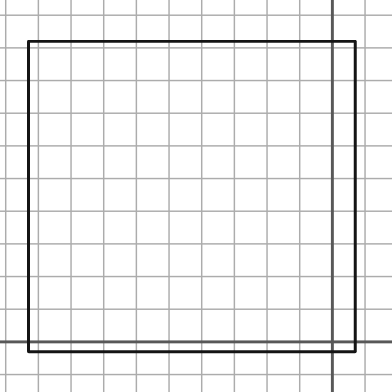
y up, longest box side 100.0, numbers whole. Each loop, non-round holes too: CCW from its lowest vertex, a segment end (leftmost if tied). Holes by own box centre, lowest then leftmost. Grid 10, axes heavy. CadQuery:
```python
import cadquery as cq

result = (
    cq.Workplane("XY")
    .moveTo(-93.0, -3.0)
    .lineTo(7.0, -3.0)
    .lineTo(7.0, 92.0)
    .lineTo(-93.0, 92.0)
    .close()
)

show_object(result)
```